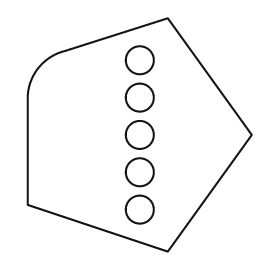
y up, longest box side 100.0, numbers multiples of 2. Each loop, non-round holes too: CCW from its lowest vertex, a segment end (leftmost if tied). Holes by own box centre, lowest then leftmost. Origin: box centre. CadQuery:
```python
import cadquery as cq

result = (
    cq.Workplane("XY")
    .moveTo(12.0, -50.0)
    .lineTo(48.0, 0.0)
    .lineTo(12.0, 50.0)
    .lineTo(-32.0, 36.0)
    .threePointArc((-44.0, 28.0), (-48.0, 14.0))
    .lineTo(-48.0, -30.0)
    .close()
    .moveTo(0.0, -32.0)
    .circle(6.0)
    .moveTo(0.0, -16.0)
    .circle(6.0)
    .moveTo(0.0, 0.0)
    .circle(6.0)
    .moveTo(0.0, 16.0)
    .circle(6.0)
    .moveTo(0.0, 32.0)
    .circle(6.0)
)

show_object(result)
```